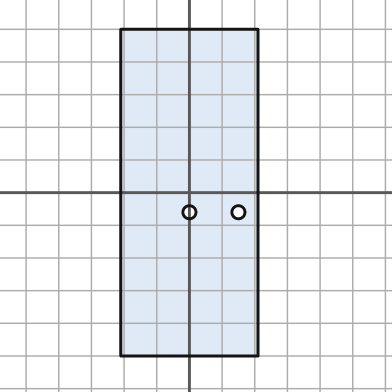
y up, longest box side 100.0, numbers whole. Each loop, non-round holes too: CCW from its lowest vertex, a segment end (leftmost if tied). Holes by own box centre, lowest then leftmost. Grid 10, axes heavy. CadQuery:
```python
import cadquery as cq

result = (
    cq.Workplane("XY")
    .moveTo(-21.0, -50.0)
    .lineTo(21.0, -50.0)
    .lineTo(21.0, 50.0)
    .lineTo(-21.0, 50.0)
    .close()
    .moveTo(0.0, -6.0)
    .circle(2.0)
    .moveTo(15.0, -6.0)
    .circle(2.0)
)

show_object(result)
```